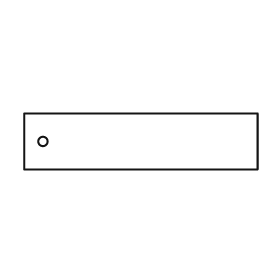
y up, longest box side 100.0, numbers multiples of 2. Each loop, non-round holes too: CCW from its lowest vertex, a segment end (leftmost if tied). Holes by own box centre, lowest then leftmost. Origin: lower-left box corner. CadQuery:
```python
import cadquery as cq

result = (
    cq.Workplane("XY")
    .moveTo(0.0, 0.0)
    .lineTo(100.0, 0.0)
    .lineTo(100.0, 24.0)
    .lineTo(0.0, 24.0)
    .close()
    .moveTo(8.0, 12.0)
    .circle(2.0)
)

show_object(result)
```